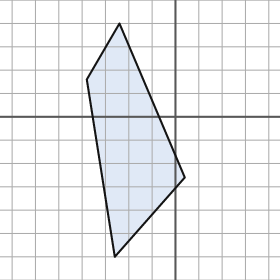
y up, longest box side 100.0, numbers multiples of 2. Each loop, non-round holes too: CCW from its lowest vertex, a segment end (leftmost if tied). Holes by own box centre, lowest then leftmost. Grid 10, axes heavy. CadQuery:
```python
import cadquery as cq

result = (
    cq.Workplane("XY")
    .moveTo(-26.0, -60.0)
    .lineTo(4.0, -26.0)
    .lineTo(-24.0, 40.0)
    .lineTo(-38.0, 16.0)
    .close()
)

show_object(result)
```